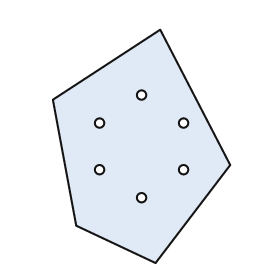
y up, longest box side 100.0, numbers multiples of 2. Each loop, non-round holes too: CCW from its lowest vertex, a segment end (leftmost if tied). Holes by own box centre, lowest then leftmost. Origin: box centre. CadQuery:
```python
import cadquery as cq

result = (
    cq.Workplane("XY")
    .moveTo(6.0, -50.0)
    .lineTo(38.0, -8.0)
    .lineTo(8.0, 50.0)
    .lineTo(-38.0, 20.0)
    .lineTo(-28.0, -34.0)
    .close()
    .moveTo(0.0, -22.0)
    .circle(2.0)
    .moveTo(-18.0, -10.0)
    .circle(2.0)
    .moveTo(18.0, -10.0)
    .circle(2.0)
    .moveTo(-18.0, 10.0)
    .circle(2.0)
    .moveTo(18.0, 10.0)
    .circle(2.0)
    .moveTo(0.0, 22.0)
    .circle(2.0)
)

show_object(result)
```